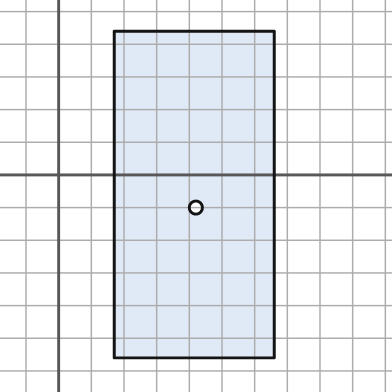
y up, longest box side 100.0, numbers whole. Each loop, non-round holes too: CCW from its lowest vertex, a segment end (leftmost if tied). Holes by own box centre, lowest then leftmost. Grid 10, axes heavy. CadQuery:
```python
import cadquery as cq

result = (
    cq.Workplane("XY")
    .moveTo(17.0, -56.0)
    .lineTo(66.0, -56.0)
    .lineTo(66.0, 44.0)
    .lineTo(17.0, 44.0)
    .close()
    .moveTo(42.0, -10.0)
    .circle(2.0)
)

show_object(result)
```